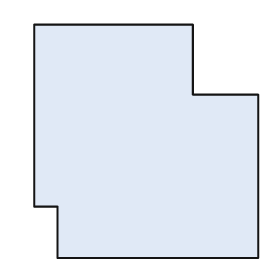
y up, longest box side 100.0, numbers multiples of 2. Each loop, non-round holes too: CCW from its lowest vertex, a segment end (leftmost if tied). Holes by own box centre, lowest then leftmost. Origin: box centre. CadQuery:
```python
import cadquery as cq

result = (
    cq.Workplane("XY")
    .moveTo(-38.0, -50.0)
    .lineTo(48.0, -50.0)
    .lineTo(48.0, 20.0)
    .lineTo(20.0, 20.0)
    .lineTo(20.0, 50.0)
    .lineTo(-48.0, 50.0)
    .lineTo(-48.0, -28.0)
    .lineTo(-38.0, -28.0)
    .close()
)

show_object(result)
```